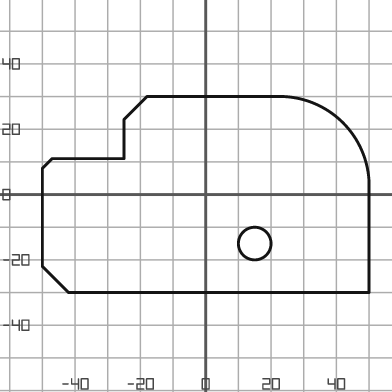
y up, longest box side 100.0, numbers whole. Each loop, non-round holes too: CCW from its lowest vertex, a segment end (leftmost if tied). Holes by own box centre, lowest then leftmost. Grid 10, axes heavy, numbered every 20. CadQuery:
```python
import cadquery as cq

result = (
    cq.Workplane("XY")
    .moveTo(-42.0, -30.0)
    .lineTo(50.0, -30.0)
    .lineTo(50.0, 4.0)
    .threePointArc((42.0, 22.0), (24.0, 30.0))
    .lineTo(-18.0, 30.0)
    .lineTo(-25.0, 23.0)
    .lineTo(-25.0, 11.0)
    .lineTo(-47.0, 11.0)
    .lineTo(-50.0, 8.0)
    .lineTo(-50.0, -22.0)
    .close()
    .moveTo(15.0, -15.0)
    .circle(5.0)
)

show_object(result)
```